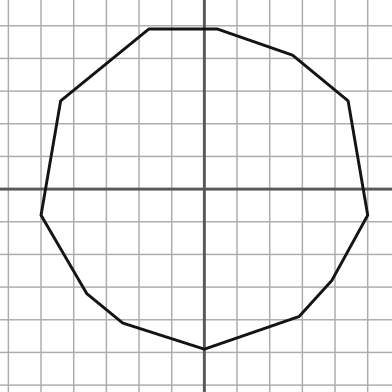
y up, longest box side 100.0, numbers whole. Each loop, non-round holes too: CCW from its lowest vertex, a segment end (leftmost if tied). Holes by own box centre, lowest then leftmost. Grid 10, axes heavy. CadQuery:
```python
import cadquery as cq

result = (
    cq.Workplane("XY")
    .moveTo(0.0, -49.0)
    .lineTo(29.0, -39.0)
    .lineTo(39.0, -28.0)
    .lineTo(50.0, -8.0)
    .lineTo(44.0, 27.0)
    .lineTo(27.0, 41.0)
    .lineTo(4.0, 49.0)
    .lineTo(-17.0, 49.0)
    .lineTo(-44.0, 27.0)
    .lineTo(-50.0, -8.0)
    .lineTo(-36.0, -32.0)
    .lineTo(-25.0, -41.0)
    .close()
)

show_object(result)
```